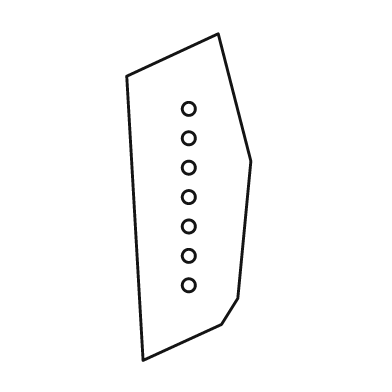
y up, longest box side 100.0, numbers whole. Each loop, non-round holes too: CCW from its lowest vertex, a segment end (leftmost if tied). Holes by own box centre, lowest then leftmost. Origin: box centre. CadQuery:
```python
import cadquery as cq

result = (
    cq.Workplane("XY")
    .moveTo(-14.0, -50.0)
    .lineTo(10.0, -39.0)
    .lineTo(15.0, -31.0)
    .lineTo(19.0, 11.0)
    .lineTo(9.0, 50.0)
    .lineTo(-19.0, 37.0)
    .close()
    .moveTo(0.0, -27.0)
    .circle(2.0)
    .moveTo(0.0, -18.0)
    .circle(2.0)
    .moveTo(0.0, -9.0)
    .circle(2.0)
    .moveTo(0.0, 0.0)
    .circle(2.0)
    .moveTo(0.0, 9.0)
    .circle(2.0)
    .moveTo(0.0, 18.0)
    .circle(2.0)
    .moveTo(0.0, 27.0)
    .circle(2.0)
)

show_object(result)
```